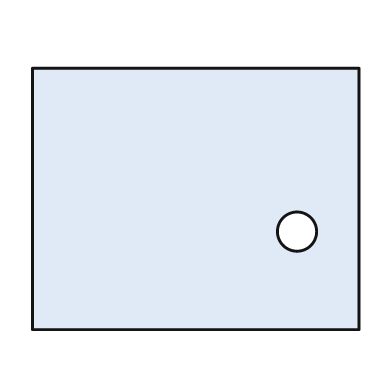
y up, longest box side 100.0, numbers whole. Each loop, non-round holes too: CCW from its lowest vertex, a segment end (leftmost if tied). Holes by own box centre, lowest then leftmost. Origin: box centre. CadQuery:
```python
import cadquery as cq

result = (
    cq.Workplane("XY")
    .moveTo(-50.0, -40.0)
    .lineTo(50.0, -40.0)
    .lineTo(50.0, 40.0)
    .lineTo(-50.0, 40.0)
    .close()
    .moveTo(31.0, -10.0)
    .circle(6.0)
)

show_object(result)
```